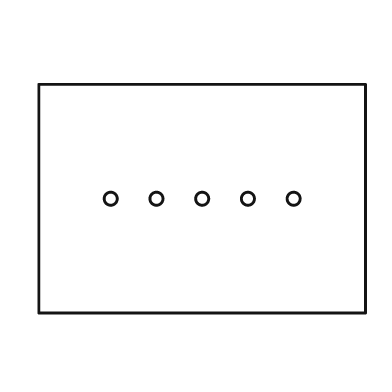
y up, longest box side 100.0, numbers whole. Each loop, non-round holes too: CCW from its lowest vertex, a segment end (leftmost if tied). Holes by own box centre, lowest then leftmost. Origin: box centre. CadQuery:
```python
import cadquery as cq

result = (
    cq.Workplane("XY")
    .moveTo(-50.0, -35.0)
    .lineTo(50.0, -35.0)
    .lineTo(50.0, 35.0)
    .lineTo(-50.0, 35.0)
    .close()
    .moveTo(-28.0, 0.0)
    .circle(2.0)
    .moveTo(-14.0, 0.0)
    .circle(2.0)
    .moveTo(0.0, 0.0)
    .circle(2.0)
    .moveTo(14.0, 0.0)
    .circle(2.0)
    .moveTo(28.0, 0.0)
    .circle(2.0)
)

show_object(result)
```